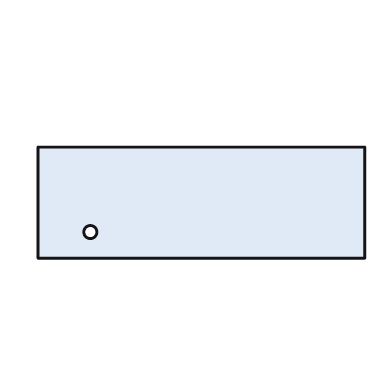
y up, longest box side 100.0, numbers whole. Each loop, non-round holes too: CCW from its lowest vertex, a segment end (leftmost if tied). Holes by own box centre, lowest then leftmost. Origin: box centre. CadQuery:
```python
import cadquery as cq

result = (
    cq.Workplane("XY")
    .moveTo(-50.0, -17.0)
    .lineTo(50.0, -17.0)
    .lineTo(50.0, 17.0)
    .lineTo(-50.0, 17.0)
    .close()
    .moveTo(-34.0, -9.0)
    .circle(2.0)
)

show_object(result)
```